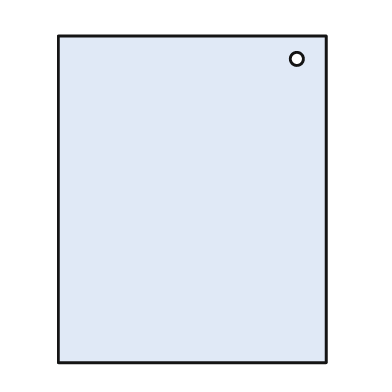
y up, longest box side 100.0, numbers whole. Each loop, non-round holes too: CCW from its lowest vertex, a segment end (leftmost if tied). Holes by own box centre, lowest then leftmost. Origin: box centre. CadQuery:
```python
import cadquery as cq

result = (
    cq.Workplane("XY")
    .moveTo(-41.0, -50.0)
    .lineTo(41.0, -50.0)
    .lineTo(41.0, 50.0)
    .lineTo(-41.0, 50.0)
    .close()
    .moveTo(32.0, 43.0)
    .circle(2.0)
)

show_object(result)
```